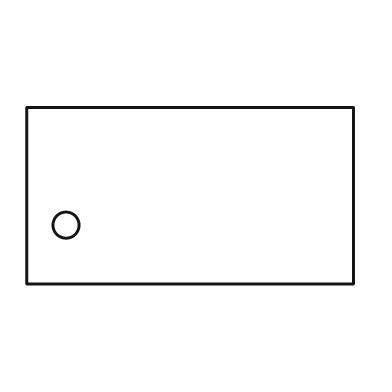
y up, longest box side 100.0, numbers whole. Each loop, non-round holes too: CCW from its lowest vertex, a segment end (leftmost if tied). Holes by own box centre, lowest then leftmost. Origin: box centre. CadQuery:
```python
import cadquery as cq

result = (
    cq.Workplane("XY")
    .moveTo(-50.0, -27.0)
    .lineTo(50.0, -27.0)
    .lineTo(50.0, 27.0)
    .lineTo(-50.0, 27.0)
    .close()
    .moveTo(-38.0, -9.0)
    .circle(4.0)
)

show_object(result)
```